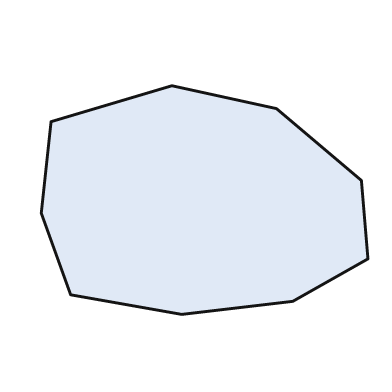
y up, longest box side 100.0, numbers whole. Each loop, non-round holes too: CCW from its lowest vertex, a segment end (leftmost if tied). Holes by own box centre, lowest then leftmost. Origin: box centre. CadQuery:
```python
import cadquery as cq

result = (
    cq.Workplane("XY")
    .moveTo(-7.0, -35.0)
    .lineTo(27.0, -31.0)
    .lineTo(50.0, -18.0)
    .lineTo(48.0, 6.0)
    .lineTo(22.0, 28.0)
    .lineTo(-10.0, 35.0)
    .lineTo(-47.0, 24.0)
    .lineTo(-50.0, -4.0)
    .lineTo(-41.0, -29.0)
    .close()
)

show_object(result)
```